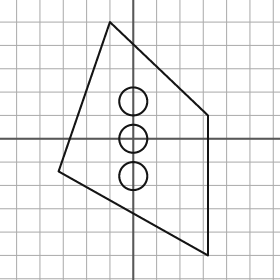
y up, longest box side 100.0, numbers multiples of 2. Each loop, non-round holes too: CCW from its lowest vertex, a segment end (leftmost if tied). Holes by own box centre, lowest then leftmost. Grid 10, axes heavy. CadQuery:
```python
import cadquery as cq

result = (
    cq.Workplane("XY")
    .moveTo(32.0, -50.0)
    .lineTo(32.0, 10.0)
    .lineTo(-10.0, 50.0)
    .lineTo(-32.0, -14.0)
    .close()
    .moveTo(0.0, -16.0)
    .circle(6.0)
    .moveTo(0.0, 0.0)
    .circle(6.0)
    .moveTo(0.0, 16.0)
    .circle(6.0)
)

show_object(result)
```